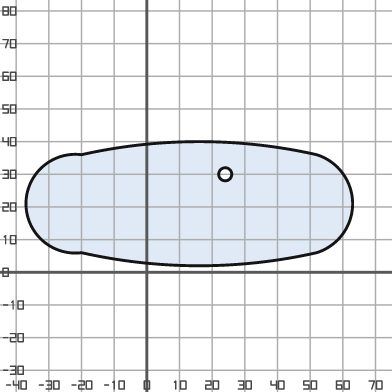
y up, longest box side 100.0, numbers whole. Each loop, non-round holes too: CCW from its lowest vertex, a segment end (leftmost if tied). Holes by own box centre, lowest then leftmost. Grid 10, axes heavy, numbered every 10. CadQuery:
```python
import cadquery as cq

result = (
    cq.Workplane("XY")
    .moveTo(-20.0, 6.0)
    .threePointArc((16.0, 2.0), (52.0, 6.0))
    .threePointArc((63.0, 21.0), (52.0, 36.0))
    .threePointArc((16.0, 40.0), (-20.0, 36.0))
    .threePointArc((-37.0, 21.0), (-20.0, 6.0))
    .close()
    .moveTo(24.0, 30.0)
    .circle(2.0)
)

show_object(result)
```